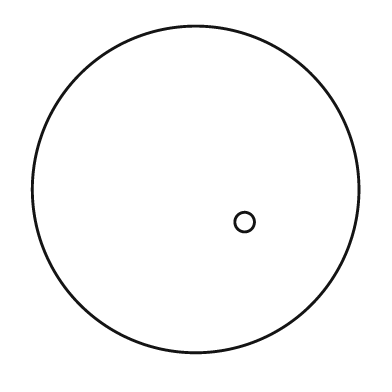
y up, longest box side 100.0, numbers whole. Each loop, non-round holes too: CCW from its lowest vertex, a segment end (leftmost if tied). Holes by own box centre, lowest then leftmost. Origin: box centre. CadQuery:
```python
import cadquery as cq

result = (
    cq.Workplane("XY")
    .moveTo(0.0, 0.0)
    .circle(50.0)
    .moveTo(15.0, -10.0)
    .circle(3.0)
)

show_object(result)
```